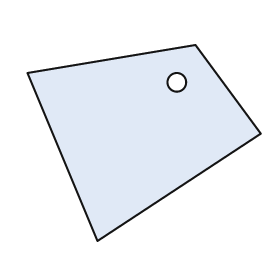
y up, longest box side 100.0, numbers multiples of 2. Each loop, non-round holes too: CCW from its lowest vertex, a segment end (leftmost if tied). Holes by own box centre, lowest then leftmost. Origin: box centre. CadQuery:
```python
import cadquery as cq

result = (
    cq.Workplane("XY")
    .moveTo(-20.0, -42.0)
    .lineTo(50.0, 4.0)
    .lineTo(22.0, 42.0)
    .lineTo(-50.0, 30.0)
    .close()
    .moveTo(14.0, 26.0)
    .circle(4.0)
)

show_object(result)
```